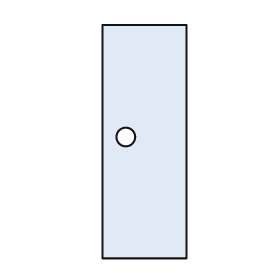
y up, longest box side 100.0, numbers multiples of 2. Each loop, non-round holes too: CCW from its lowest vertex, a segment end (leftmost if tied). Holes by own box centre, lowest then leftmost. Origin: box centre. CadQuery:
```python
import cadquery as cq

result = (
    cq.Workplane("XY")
    .moveTo(-18.0, -50.0)
    .lineTo(18.0, -50.0)
    .lineTo(18.0, 50.0)
    .lineTo(-18.0, 50.0)
    .close()
    .moveTo(-8.0, 2.0)
    .circle(4.0)
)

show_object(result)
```